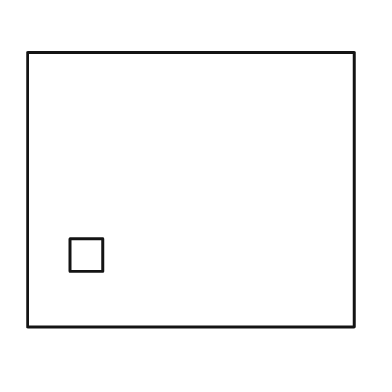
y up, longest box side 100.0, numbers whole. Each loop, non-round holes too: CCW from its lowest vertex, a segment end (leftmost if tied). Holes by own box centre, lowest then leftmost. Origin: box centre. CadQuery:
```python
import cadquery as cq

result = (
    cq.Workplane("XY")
    .moveTo(-50.0, -42.0)
    .lineTo(50.0, -42.0)
    .lineTo(50.0, 42.0)
    .lineTo(-50.0, 42.0)
    .close()
    .moveTo(-37.0, -25.0)
    .lineTo(-27.0, -25.0)
    .lineTo(-27.0, -15.0)
    .lineTo(-37.0, -15.0)
    .close()
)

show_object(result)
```